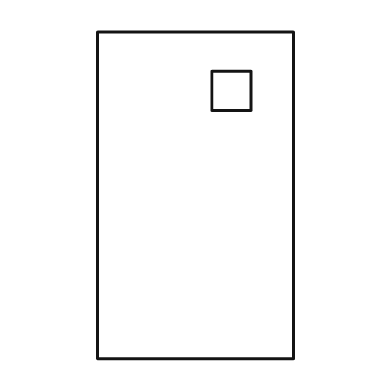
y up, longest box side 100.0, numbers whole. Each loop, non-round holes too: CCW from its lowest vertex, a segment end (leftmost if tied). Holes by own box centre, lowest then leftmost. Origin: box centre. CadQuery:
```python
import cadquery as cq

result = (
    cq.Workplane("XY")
    .moveTo(-30.0, -50.0)
    .lineTo(30.0, -50.0)
    .lineTo(30.0, 50.0)
    .lineTo(-30.0, 50.0)
    .close()
    .moveTo(5.0, 26.0)
    .lineTo(17.0, 26.0)
    .lineTo(17.0, 38.0)
    .lineTo(5.0, 38.0)
    .close()
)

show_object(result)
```